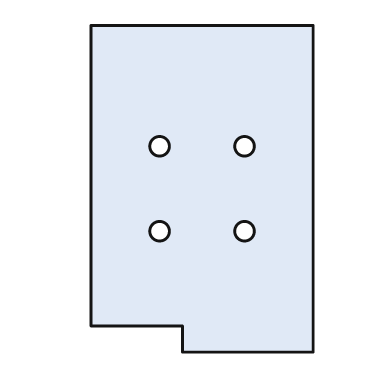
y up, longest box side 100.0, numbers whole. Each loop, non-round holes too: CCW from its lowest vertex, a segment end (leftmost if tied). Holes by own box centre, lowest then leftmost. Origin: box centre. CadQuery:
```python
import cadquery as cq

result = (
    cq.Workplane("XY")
    .moveTo(-6.0, -50.0)
    .lineTo(34.0, -50.0)
    .lineTo(34.0, 50.0)
    .lineTo(-34.0, 50.0)
    .lineTo(-34.0, -42.0)
    .lineTo(-6.0, -42.0)
    .close()
    .moveTo(-13.0, -13.0)
    .circle(3.0)
    .moveTo(13.0, -13.0)
    .circle(3.0)
    .moveTo(-13.0, 13.0)
    .circle(3.0)
    .moveTo(13.0, 13.0)
    .circle(3.0)
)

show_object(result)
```